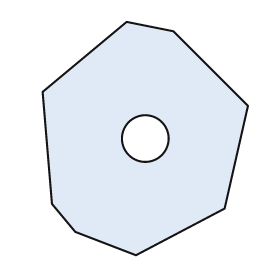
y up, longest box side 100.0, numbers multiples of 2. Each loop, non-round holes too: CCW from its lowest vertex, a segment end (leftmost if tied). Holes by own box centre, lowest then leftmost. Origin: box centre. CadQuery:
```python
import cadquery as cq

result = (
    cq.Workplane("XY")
    .moveTo(-4.0, -50.0)
    .lineTo(34.0, -30.0)
    .lineTo(44.0, 14.0)
    .lineTo(12.0, 46.0)
    .lineTo(-8.0, 50.0)
    .lineTo(-44.0, 20.0)
    .lineTo(-40.0, -28.0)
    .lineTo(-30.0, -40.0)
    .close()
    .moveTo(0.0, 0.0)
    .circle(10.0)
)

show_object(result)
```